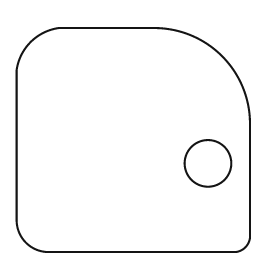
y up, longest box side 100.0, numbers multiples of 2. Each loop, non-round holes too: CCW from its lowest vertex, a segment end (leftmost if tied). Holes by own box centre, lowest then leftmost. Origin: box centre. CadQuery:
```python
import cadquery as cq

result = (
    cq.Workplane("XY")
    .moveTo(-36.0, -48.0)
    .lineTo(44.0, -48.0)
    .threePointArc((48.0, -46.0), (50.0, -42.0))
    .lineTo(50.0, 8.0)
    .threePointArc((38.0, 36.0), (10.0, 48.0))
    .lineTo(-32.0, 48.0)
    .threePointArc((-44.0, 42.0), (-50.0, 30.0))
    .lineTo(-50.0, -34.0)
    .threePointArc((-46.0, -44.0), (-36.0, -48.0))
    .close()
    .moveTo(32.0, -10.0)
    .circle(10.0)
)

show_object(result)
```